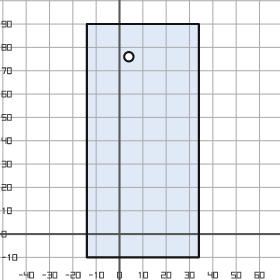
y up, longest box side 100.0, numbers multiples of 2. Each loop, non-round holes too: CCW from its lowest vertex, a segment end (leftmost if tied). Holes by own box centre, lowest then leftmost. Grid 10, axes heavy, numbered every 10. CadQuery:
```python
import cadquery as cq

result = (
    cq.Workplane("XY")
    .moveTo(-14.0, -10.0)
    .lineTo(34.0, -10.0)
    .lineTo(34.0, 90.0)
    .lineTo(-14.0, 90.0)
    .close()
    .moveTo(4.0, 76.0)
    .circle(2.0)
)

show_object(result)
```